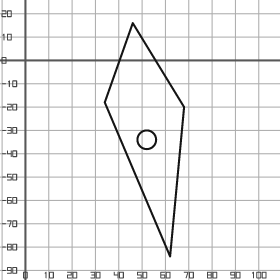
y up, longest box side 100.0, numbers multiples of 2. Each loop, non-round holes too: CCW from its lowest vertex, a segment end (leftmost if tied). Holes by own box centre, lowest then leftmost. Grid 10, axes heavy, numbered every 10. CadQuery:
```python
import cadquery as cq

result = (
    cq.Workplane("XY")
    .moveTo(62.0, -84.0)
    .lineTo(68.0, -20.0)
    .lineTo(46.0, 16.0)
    .lineTo(34.0, -18.0)
    .close()
    .moveTo(52.0, -34.0)
    .circle(4.0)
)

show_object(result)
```